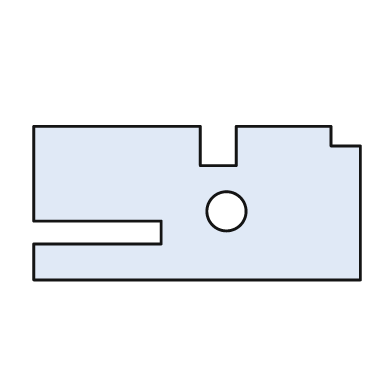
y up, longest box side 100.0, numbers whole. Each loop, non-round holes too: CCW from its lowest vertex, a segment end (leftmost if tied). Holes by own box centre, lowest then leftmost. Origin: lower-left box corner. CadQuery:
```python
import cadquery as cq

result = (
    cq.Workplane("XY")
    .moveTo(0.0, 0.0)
    .lineTo(100.0, 0.0)
    .lineTo(100.0, 41.0)
    .lineTo(91.0, 41.0)
    .lineTo(91.0, 47.0)
    .lineTo(62.0, 47.0)
    .lineTo(62.0, 35.0)
    .lineTo(51.0, 35.0)
    .lineTo(51.0, 47.0)
    .lineTo(0.0, 47.0)
    .lineTo(0.0, 18.0)
    .lineTo(39.0, 18.0)
    .lineTo(39.0, 11.0)
    .lineTo(0.0, 11.0)
    .close()
    .moveTo(59.0, 21.0)
    .circle(6.0)
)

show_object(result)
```